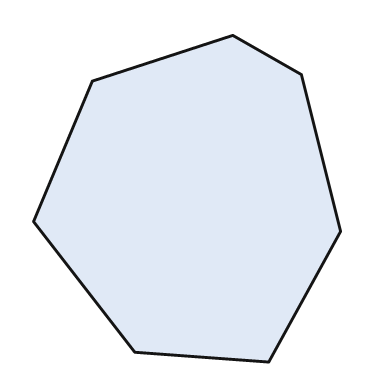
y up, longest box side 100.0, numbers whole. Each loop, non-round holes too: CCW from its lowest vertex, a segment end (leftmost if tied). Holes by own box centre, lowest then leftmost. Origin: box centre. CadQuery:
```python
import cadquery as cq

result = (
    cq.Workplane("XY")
    .moveTo(25.0, -50.0)
    .lineTo(47.0, -10.0)
    .lineTo(35.0, 38.0)
    .lineTo(14.0, 50.0)
    .lineTo(-29.0, 36.0)
    .lineTo(-47.0, -7.0)
    .lineTo(-16.0, -47.0)
    .close()
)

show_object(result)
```